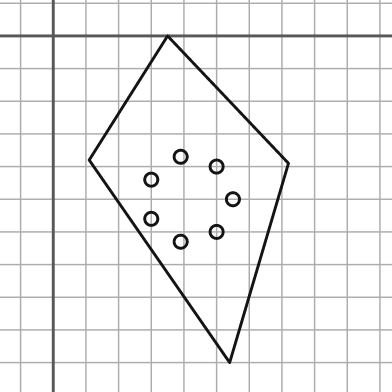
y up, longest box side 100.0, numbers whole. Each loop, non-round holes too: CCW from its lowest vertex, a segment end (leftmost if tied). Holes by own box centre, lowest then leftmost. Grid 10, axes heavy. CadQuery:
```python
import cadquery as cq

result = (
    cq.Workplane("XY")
    .moveTo(54.0, -100.0)
    .lineTo(72.0, -39.0)
    .lineTo(35.0, 0.0)
    .lineTo(11.0, -38.0)
    .close()
    .moveTo(39.0, -63.0)
    .circle(2.0)
    .moveTo(50.0, -60.0)
    .circle(2.0)
    .moveTo(30.0, -56.0)
    .circle(2.0)
    .moveTo(55.0, -50.0)
    .circle(2.0)
    .moveTo(30.0, -44.0)
    .circle(2.0)
    .moveTo(50.0, -40.0)
    .circle(2.0)
    .moveTo(39.0, -37.0)
    .circle(2.0)
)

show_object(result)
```